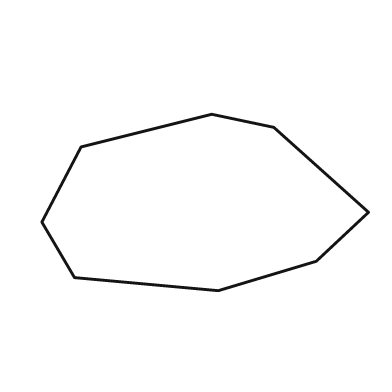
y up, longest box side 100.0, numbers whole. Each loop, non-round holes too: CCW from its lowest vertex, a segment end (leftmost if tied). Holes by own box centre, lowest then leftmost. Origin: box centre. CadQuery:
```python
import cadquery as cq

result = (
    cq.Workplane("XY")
    .moveTo(4.0, -27.0)
    .lineTo(34.0, -18.0)
    .lineTo(50.0, -3.0)
    .lineTo(21.0, 23.0)
    .lineTo(2.0, 27.0)
    .lineTo(-38.0, 17.0)
    .lineTo(-50.0, -6.0)
    .lineTo(-40.0, -23.0)
    .close()
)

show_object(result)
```